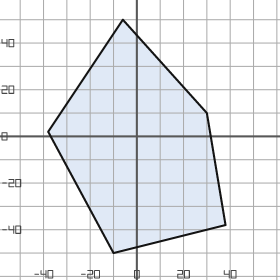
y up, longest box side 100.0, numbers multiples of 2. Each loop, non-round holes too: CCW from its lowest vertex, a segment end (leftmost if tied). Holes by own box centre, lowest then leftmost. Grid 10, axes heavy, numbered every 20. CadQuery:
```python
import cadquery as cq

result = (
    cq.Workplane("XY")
    .moveTo(-10.0, -50.0)
    .lineTo(38.0, -38.0)
    .lineTo(30.0, 10.0)
    .lineTo(-6.0, 50.0)
    .lineTo(-38.0, 2.0)
    .close()
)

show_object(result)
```